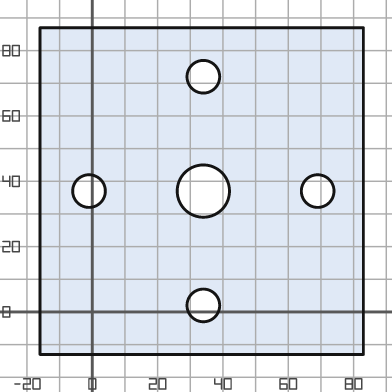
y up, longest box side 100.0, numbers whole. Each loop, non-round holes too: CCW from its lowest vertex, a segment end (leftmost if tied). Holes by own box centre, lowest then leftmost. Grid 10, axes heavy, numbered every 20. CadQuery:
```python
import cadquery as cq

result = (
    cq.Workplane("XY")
    .moveTo(-16.0, -13.0)
    .lineTo(83.0, -13.0)
    .lineTo(83.0, 87.0)
    .lineTo(-16.0, 87.0)
    .close()
    .moveTo(34.0, 2.0)
    .circle(5.0)
    .moveTo(-1.0, 37.0)
    .circle(5.0)
    .moveTo(34.0, 37.0)
    .circle(8.0)
    .moveTo(69.0, 37.0)
    .circle(5.0)
    .moveTo(34.0, 72.0)
    .circle(5.0)
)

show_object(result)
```